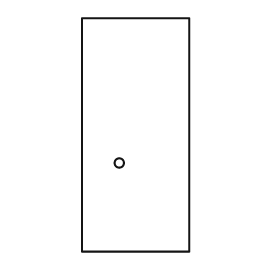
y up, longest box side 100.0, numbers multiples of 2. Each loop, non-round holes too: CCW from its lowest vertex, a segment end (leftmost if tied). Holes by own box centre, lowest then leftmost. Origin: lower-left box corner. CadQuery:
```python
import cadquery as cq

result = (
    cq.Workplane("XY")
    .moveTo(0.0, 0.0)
    .lineTo(46.0, 0.0)
    .lineTo(46.0, 100.0)
    .lineTo(0.0, 100.0)
    .close()
    .moveTo(16.0, 38.0)
    .circle(2.0)
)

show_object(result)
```